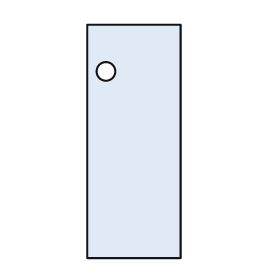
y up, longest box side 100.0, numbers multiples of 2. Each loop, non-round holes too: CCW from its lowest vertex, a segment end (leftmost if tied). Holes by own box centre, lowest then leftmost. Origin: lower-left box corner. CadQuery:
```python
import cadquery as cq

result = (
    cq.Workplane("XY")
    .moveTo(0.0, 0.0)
    .lineTo(40.0, 0.0)
    .lineTo(40.0, 100.0)
    .lineTo(0.0, 100.0)
    .close()
    .moveTo(8.0, 80.0)
    .circle(4.0)
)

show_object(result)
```